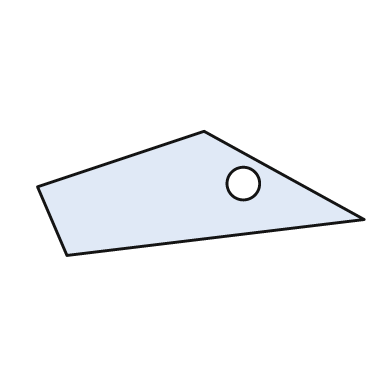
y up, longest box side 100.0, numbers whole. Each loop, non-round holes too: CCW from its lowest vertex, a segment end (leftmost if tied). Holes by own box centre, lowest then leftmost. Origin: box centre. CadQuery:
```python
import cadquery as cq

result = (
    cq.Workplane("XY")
    .moveTo(-41.0, -19.0)
    .lineTo(50.0, -8.0)
    .lineTo(1.0, 19.0)
    .lineTo(-50.0, 2.0)
    .close()
    .moveTo(13.0, 3.0)
    .circle(5.0)
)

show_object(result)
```